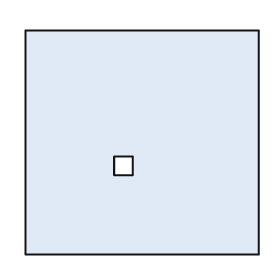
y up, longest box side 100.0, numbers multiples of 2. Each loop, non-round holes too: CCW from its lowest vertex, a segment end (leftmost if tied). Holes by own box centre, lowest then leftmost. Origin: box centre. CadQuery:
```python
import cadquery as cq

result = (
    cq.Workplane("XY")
    .moveTo(-50.0, -48.0)
    .lineTo(50.0, -48.0)
    .lineTo(50.0, 48.0)
    .lineTo(-50.0, 48.0)
    .close()
    .moveTo(-12.0, -14.0)
    .lineTo(-4.0, -14.0)
    .lineTo(-4.0, -6.0)
    .lineTo(-12.0, -6.0)
    .close()
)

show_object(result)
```